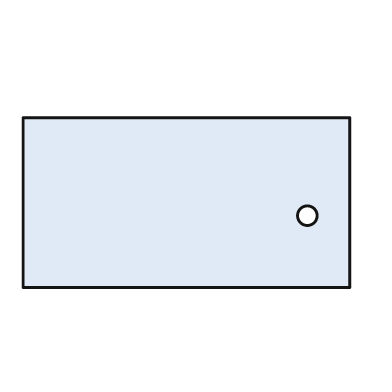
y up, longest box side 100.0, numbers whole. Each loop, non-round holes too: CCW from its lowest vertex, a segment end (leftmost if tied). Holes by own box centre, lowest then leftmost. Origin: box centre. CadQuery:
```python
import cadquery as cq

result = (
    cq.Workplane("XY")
    .moveTo(-50.0, -26.0)
    .lineTo(50.0, -26.0)
    .lineTo(50.0, 26.0)
    .lineTo(-50.0, 26.0)
    .close()
    .moveTo(37.0, -4.0)
    .circle(3.0)
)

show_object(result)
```